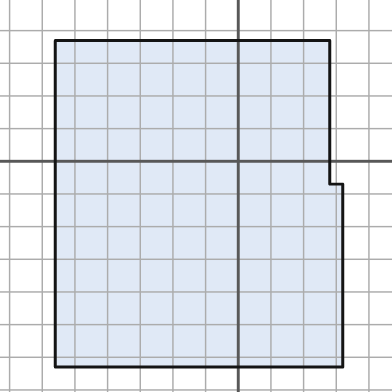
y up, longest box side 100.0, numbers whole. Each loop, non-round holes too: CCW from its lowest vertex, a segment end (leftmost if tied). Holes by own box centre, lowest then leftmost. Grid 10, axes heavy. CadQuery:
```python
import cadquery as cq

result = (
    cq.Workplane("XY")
    .moveTo(-56.0, -63.0)
    .lineTo(32.0, -63.0)
    .lineTo(32.0, -7.0)
    .lineTo(28.0, -7.0)
    .lineTo(28.0, 37.0)
    .lineTo(-56.0, 37.0)
    .close()
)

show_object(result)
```